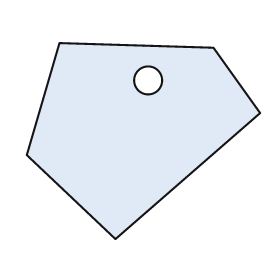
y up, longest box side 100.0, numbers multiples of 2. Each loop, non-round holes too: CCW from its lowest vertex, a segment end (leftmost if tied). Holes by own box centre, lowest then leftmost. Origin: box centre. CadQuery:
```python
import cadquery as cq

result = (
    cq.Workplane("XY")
    .moveTo(-12.0, -42.0)
    .lineTo(50.0, 12.0)
    .lineTo(30.0, 40.0)
    .lineTo(-36.0, 42.0)
    .lineTo(-50.0, -6.0)
    .close()
    .moveTo(2.0, 26.0)
    .circle(6.0)
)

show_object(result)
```